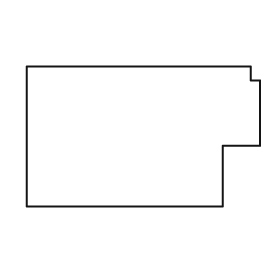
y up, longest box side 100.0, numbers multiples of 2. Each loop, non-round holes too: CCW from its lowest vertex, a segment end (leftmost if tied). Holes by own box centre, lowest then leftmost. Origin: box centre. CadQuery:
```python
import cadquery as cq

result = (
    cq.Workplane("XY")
    .moveTo(-50.0, -30.0)
    .lineTo(34.0, -30.0)
    .lineTo(34.0, -4.0)
    .lineTo(50.0, -4.0)
    .lineTo(50.0, 24.0)
    .lineTo(46.0, 24.0)
    .lineTo(46.0, 30.0)
    .lineTo(-50.0, 30.0)
    .close()
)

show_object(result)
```